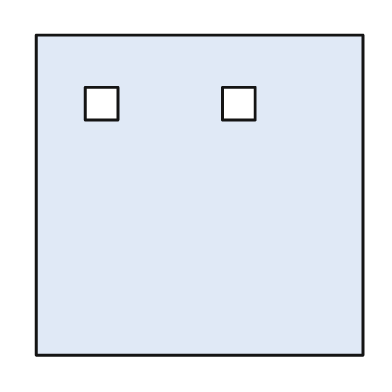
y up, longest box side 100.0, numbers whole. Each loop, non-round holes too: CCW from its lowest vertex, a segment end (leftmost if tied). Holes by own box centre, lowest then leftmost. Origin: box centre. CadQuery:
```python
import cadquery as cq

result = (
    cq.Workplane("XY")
    .moveTo(-50.0, -49.0)
    .lineTo(50.0, -49.0)
    .lineTo(50.0, 49.0)
    .lineTo(-50.0, 49.0)
    .close()
    .moveTo(-35.0, 23.0)
    .lineTo(-25.0, 23.0)
    .lineTo(-25.0, 33.0)
    .lineTo(-35.0, 33.0)
    .close()
    .moveTo(7.0, 23.0)
    .lineTo(17.0, 23.0)
    .lineTo(17.0, 33.0)
    .lineTo(7.0, 33.0)
    .close()
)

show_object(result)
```